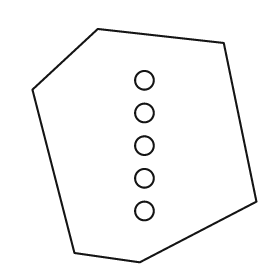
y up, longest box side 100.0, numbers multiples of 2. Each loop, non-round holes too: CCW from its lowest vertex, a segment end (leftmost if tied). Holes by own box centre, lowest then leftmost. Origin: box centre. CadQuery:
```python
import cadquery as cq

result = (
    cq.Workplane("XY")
    .moveTo(-2.0, -50.0)
    .lineTo(48.0, -24.0)
    .lineTo(34.0, 44.0)
    .lineTo(-20.0, 50.0)
    .lineTo(-48.0, 24.0)
    .lineTo(-30.0, -46.0)
    .close()
    .moveTo(0.0, -28.0)
    .circle(4.0)
    .moveTo(0.0, -14.0)
    .circle(4.0)
    .moveTo(0.0, 0.0)
    .circle(4.0)
    .moveTo(0.0, 14.0)
    .circle(4.0)
    .moveTo(0.0, 28.0)
    .circle(4.0)
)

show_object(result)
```